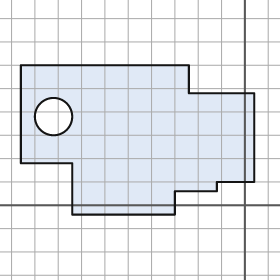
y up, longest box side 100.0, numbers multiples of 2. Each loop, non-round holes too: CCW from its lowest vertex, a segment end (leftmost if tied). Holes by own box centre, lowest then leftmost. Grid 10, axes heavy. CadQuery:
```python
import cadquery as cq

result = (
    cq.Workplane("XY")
    .moveTo(-74.0, -4.0)
    .lineTo(-30.0, -4.0)
    .lineTo(-30.0, 6.0)
    .lineTo(-12.0, 6.0)
    .lineTo(-12.0, 10.0)
    .lineTo(4.0, 10.0)
    .lineTo(4.0, 48.0)
    .lineTo(-24.0, 48.0)
    .lineTo(-24.0, 60.0)
    .lineTo(-96.0, 60.0)
    .lineTo(-96.0, 18.0)
    .lineTo(-74.0, 18.0)
    .close()
    .moveTo(-82.0, 38.0)
    .circle(8.0)
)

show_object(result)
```